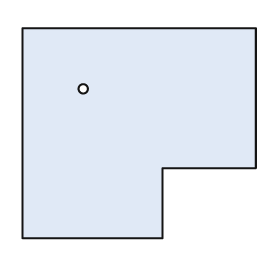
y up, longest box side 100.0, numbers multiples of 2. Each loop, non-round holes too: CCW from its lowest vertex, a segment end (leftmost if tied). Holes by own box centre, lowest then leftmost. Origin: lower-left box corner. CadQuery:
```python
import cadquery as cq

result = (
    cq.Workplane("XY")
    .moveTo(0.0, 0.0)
    .lineTo(60.0, 0.0)
    .lineTo(60.0, 30.0)
    .lineTo(100.0, 30.0)
    .lineTo(100.0, 90.0)
    .lineTo(0.0, 90.0)
    .close()
    .moveTo(26.0, 64.0)
    .circle(2.0)
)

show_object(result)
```